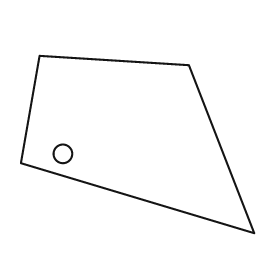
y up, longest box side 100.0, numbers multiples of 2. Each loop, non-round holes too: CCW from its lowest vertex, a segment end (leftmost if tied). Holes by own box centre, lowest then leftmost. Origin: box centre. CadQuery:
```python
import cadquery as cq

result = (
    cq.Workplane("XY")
    .moveTo(50.0, -38.0)
    .lineTo(22.0, 34.0)
    .lineTo(-42.0, 38.0)
    .lineTo(-50.0, -8.0)
    .close()
    .moveTo(-32.0, -4.0)
    .circle(4.0)
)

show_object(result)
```